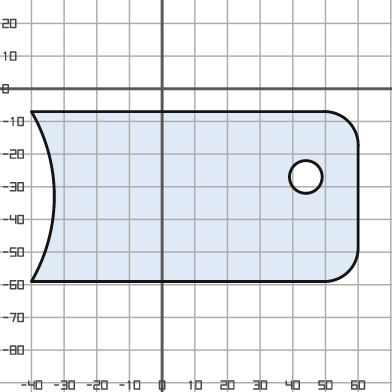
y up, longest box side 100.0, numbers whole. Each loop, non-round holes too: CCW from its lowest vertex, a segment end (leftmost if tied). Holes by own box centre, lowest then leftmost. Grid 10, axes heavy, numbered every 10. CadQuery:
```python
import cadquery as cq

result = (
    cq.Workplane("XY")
    .moveTo(-40.0, -59.0)
    .lineTo(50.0, -59.0)
    .threePointArc((57.0, -56.0), (60.0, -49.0))
    .lineTo(60.0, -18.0)
    .threePointArc((57.0, -10.0), (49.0, -7.0))
    .lineTo(-40.0, -7.0)
    .threePointArc((-33.0, -33.0), (-40.0, -59.0))
    .close()
    .moveTo(44.0, -27.0)
    .circle(5.0)
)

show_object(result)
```